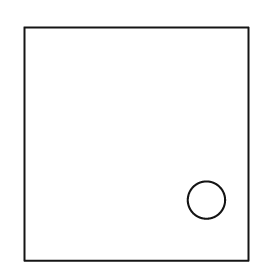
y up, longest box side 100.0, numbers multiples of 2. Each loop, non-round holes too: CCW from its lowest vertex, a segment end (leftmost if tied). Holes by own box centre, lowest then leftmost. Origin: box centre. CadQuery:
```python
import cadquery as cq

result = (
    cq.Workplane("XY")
    .moveTo(-48.0, -50.0)
    .lineTo(48.0, -50.0)
    .lineTo(48.0, 50.0)
    .lineTo(-48.0, 50.0)
    .close()
    .moveTo(30.0, -24.0)
    .circle(8.0)
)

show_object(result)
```